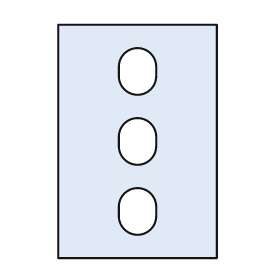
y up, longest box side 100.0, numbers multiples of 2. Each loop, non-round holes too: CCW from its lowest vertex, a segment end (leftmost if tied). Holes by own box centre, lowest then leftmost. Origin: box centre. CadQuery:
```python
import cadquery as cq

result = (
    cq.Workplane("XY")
    .moveTo(-34.0, -50.0)
    .lineTo(34.0, -50.0)
    .lineTo(34.0, 50.0)
    .lineTo(-34.0, 50.0)
    .close()
    .moveTo(-8.0, -32.0)
    .threePointArc((0.0, -40.0), (8.0, -32.0))
    .lineTo(8.0, -28.0)
    .threePointArc((0.0, -20.0), (-8.0, -28.0))
    .close()
    .moveTo(-8.0, -2.0)
    .threePointArc((0.0, -10.0), (8.0, -2.0))
    .lineTo(8.0, 2.0)
    .threePointArc((0.0, 10.0), (-8.0, 2.0))
    .close()
    .moveTo(-8.0, 28.0)
    .threePointArc((0.0, 20.0), (8.0, 28.0))
    .lineTo(8.0, 32.0)
    .threePointArc((0.0, 40.0), (-8.0, 32.0))
    .close()
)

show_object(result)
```